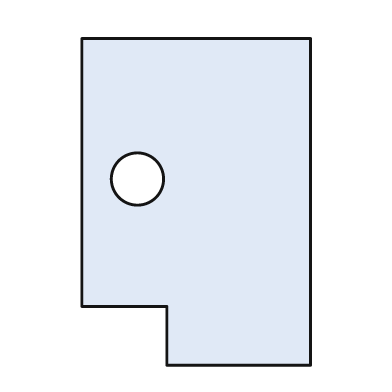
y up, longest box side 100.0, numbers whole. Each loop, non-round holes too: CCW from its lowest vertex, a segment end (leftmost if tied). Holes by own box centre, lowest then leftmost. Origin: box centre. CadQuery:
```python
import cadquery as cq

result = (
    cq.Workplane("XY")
    .moveTo(-9.0, -50.0)
    .lineTo(35.0, -50.0)
    .lineTo(35.0, 50.0)
    .lineTo(-35.0, 50.0)
    .lineTo(-35.0, -32.0)
    .lineTo(-9.0, -32.0)
    .close()
    .moveTo(-18.0, 7.0)
    .circle(8.0)
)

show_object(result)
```